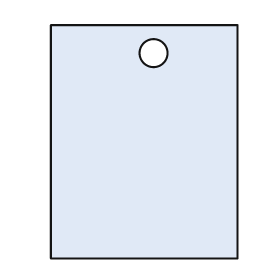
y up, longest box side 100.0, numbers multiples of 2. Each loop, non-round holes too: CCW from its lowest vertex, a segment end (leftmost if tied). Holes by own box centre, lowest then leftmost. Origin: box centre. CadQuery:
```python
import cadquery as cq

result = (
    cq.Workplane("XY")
    .moveTo(-40.0, -50.0)
    .lineTo(40.0, -50.0)
    .lineTo(40.0, 50.0)
    .lineTo(-40.0, 50.0)
    .close()
    .moveTo(4.0, 38.0)
    .circle(6.0)
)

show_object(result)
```